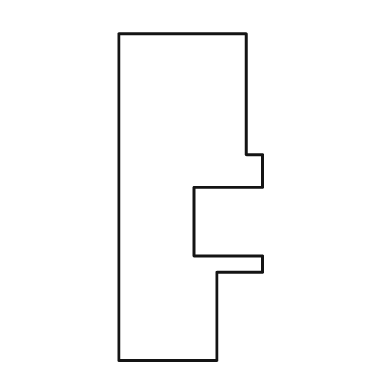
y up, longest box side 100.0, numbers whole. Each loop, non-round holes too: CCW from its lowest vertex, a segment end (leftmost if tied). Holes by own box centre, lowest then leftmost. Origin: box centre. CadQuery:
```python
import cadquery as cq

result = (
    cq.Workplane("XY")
    .moveTo(-22.0, -50.0)
    .lineTo(8.0, -50.0)
    .lineTo(8.0, -23.0)
    .lineTo(22.0, -23.0)
    .lineTo(22.0, -18.0)
    .lineTo(1.0, -18.0)
    .lineTo(1.0, 3.0)
    .lineTo(22.0, 3.0)
    .lineTo(22.0, 13.0)
    .lineTo(17.0, 13.0)
    .lineTo(17.0, 50.0)
    .lineTo(-22.0, 50.0)
    .close()
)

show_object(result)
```